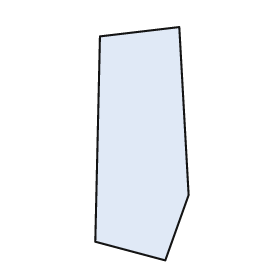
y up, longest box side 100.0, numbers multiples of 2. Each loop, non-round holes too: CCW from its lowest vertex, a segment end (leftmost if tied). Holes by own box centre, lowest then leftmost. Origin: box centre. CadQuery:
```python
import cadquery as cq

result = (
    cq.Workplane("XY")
    .moveTo(10.0, -50.0)
    .lineTo(20.0, -22.0)
    .lineTo(16.0, 50.0)
    .lineTo(-18.0, 46.0)
    .lineTo(-20.0, -42.0)
    .close()
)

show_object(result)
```